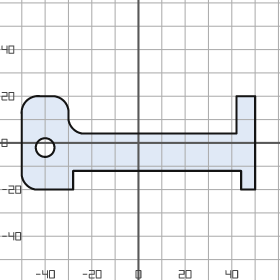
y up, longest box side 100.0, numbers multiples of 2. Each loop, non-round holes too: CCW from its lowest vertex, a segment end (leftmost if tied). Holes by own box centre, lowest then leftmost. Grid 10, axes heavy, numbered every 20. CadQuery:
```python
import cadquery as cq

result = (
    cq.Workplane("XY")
    .moveTo(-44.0, -20.0)
    .lineTo(-28.0, -20.0)
    .lineTo(-28.0, -12.0)
    .lineTo(44.0, -12.0)
    .lineTo(44.0, -20.0)
    .lineTo(50.0, -20.0)
    .lineTo(50.0, 20.0)
    .lineTo(42.0, 20.0)
    .lineTo(42.0, 4.0)
    .lineTo(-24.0, 4.0)
    .threePointArc((-28.0, 6.0), (-30.0, 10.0))
    .lineTo(-30.0, 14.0)
    .threePointArc((-32.0, 18.0), (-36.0, 20.0))
    .lineTo(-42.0, 20.0)
    .threePointArc((-48.0, 18.0), (-50.0, 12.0))
    .lineTo(-50.0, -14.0)
    .threePointArc((-48.0, -18.0), (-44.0, -20.0))
    .close()
    .moveTo(-40.0, -2.0)
    .circle(4.0)
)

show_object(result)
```